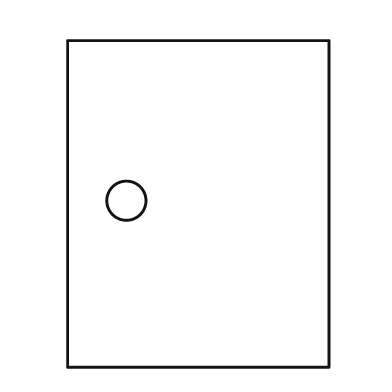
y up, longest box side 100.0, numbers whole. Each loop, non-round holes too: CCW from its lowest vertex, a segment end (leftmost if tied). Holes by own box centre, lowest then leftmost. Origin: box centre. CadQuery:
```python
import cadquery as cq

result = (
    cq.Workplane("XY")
    .moveTo(-40.0, -50.0)
    .lineTo(40.0, -50.0)
    .lineTo(40.0, 50.0)
    .lineTo(-40.0, 50.0)
    .close()
    .moveTo(-22.0, 1.0)
    .circle(6.0)
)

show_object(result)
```